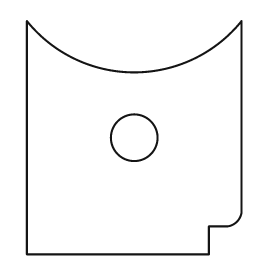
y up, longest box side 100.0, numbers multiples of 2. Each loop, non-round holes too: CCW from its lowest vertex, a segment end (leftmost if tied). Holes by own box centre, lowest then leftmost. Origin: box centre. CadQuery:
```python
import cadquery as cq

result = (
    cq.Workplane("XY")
    .moveTo(-46.0, -50.0)
    .lineTo(32.0, -50.0)
    .lineTo(32.0, -38.0)
    .lineTo(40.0, -38.0)
    .threePointArc((44.0, -36.0), (46.0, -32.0))
    .lineTo(46.0, 50.0)
    .threePointArc((0.0, 28.0), (-46.0, 50.0))
    .close()
    .moveTo(0.0, 0.0)
    .circle(10.0)
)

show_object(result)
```